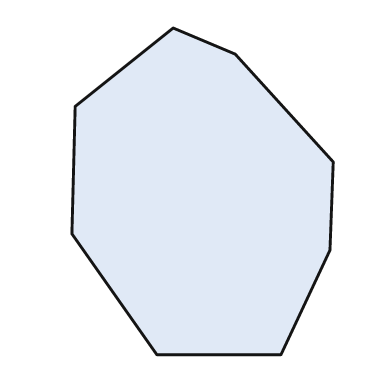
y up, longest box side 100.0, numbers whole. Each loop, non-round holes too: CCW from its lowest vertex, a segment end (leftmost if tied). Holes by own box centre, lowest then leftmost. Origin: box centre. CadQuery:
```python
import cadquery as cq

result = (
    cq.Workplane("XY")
    .moveTo(-14.0, -50.0)
    .lineTo(24.0, -50.0)
    .lineTo(39.0, -18.0)
    .lineTo(40.0, 9.0)
    .lineTo(10.0, 42.0)
    .lineTo(-9.0, 50.0)
    .lineTo(-39.0, 26.0)
    .lineTo(-40.0, -13.0)
    .close()
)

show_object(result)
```